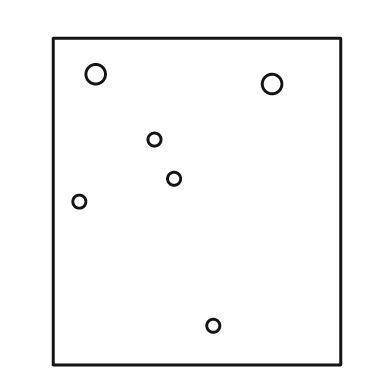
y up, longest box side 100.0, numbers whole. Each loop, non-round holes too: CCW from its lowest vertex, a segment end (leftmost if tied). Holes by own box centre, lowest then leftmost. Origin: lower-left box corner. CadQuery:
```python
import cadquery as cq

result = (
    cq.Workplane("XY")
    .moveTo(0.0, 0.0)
    .lineTo(88.0, 0.0)
    .lineTo(88.0, 100.0)
    .lineTo(0.0, 100.0)
    .close()
    .moveTo(49.0, 12.0)
    .circle(2.0)
    .moveTo(8.0, 50.0)
    .circle(2.0)
    .moveTo(37.0, 57.0)
    .circle(2.0)
    .moveTo(31.0, 69.0)
    .circle(2.0)
    .moveTo(67.0, 86.0)
    .circle(3.0)
    .moveTo(13.0, 89.0)
    .circle(3.0)
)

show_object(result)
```